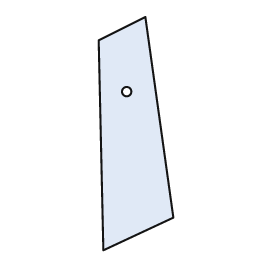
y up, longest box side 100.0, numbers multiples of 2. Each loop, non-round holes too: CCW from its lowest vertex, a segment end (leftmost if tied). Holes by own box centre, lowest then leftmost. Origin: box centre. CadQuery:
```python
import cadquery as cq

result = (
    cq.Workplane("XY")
    .moveTo(-14.0, -50.0)
    .lineTo(16.0, -36.0)
    .lineTo(4.0, 50.0)
    .lineTo(-16.0, 40.0)
    .close()
    .moveTo(-4.0, 18.0)
    .circle(2.0)
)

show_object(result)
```